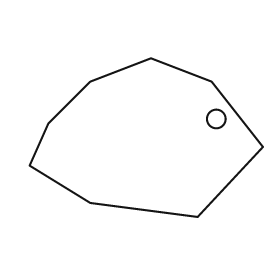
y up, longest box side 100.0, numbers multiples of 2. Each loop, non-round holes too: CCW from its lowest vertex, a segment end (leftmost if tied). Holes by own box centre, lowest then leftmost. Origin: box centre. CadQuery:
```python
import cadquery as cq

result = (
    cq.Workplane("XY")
    .moveTo(22.0, -34.0)
    .lineTo(50.0, -4.0)
    .lineTo(28.0, 24.0)
    .lineTo(2.0, 34.0)
    .lineTo(-24.0, 24.0)
    .lineTo(-42.0, 6.0)
    .lineTo(-50.0, -12.0)
    .lineTo(-24.0, -28.0)
    .close()
    .moveTo(30.0, 8.0)
    .circle(4.0)
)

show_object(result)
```